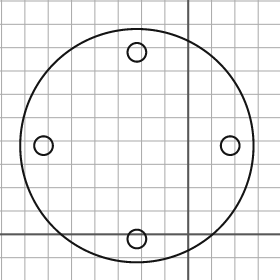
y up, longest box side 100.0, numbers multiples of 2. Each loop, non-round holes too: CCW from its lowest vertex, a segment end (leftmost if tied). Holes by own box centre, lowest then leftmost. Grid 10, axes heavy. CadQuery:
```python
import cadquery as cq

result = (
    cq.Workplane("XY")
    .moveTo(-22.0, 38.0)
    .circle(50.0)
    .moveTo(-22.0, -2.0)
    .circle(4.0)
    .moveTo(-62.0, 38.0)
    .circle(4.0)
    .moveTo(18.0, 38.0)
    .circle(4.0)
    .moveTo(-22.0, 78.0)
    .circle(4.0)
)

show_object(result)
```